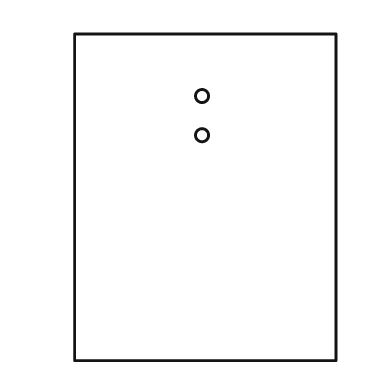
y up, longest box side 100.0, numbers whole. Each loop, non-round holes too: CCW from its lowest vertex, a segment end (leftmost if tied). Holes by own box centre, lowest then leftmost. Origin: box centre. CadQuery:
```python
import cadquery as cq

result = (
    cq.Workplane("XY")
    .moveTo(-40.0, -50.0)
    .lineTo(40.0, -50.0)
    .lineTo(40.0, 50.0)
    .lineTo(-40.0, 50.0)
    .close()
    .moveTo(-1.0, 19.0)
    .circle(2.0)
    .moveTo(-1.0, 31.0)
    .circle(2.0)
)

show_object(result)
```